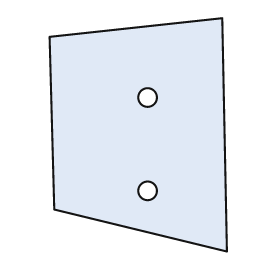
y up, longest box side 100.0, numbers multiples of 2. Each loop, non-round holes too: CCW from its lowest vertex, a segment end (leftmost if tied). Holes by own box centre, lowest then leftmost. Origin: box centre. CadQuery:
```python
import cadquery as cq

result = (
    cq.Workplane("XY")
    .moveTo(38.0, -50.0)
    .lineTo(36.0, 50.0)
    .lineTo(-38.0, 42.0)
    .lineTo(-36.0, -32.0)
    .close()
    .moveTo(4.0, -24.0)
    .circle(4.0)
    .moveTo(4.0, 16.0)
    .circle(4.0)
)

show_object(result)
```